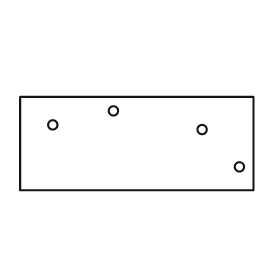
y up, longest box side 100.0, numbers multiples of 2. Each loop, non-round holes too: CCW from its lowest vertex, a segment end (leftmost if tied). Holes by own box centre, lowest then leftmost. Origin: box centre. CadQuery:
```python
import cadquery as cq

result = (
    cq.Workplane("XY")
    .moveTo(-50.0, -20.0)
    .lineTo(50.0, -20.0)
    .lineTo(50.0, 20.0)
    .lineTo(-50.0, 20.0)
    .close()
    .moveTo(44.0, -10.0)
    .circle(2.0)
    .moveTo(28.0, 6.0)
    .circle(2.0)
    .moveTo(-36.0, 8.0)
    .circle(2.0)
    .moveTo(-10.0, 14.0)
    .circle(2.0)
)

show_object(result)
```